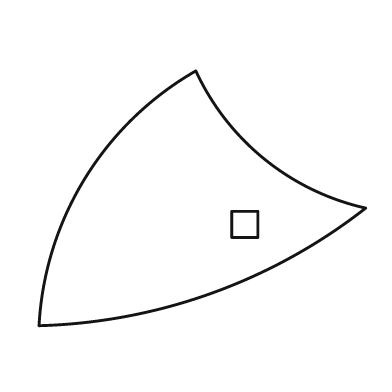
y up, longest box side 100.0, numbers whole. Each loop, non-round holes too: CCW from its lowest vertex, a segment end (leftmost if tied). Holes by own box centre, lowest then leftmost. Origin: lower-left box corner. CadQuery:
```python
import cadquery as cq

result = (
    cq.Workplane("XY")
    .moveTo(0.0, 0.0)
    .threePointArc((53.0, 10.0), (100.0, 36.0))
    .threePointArc((69.0, 51.0), (48.0, 78.0))
    .threePointArc((14.0, 45.0), (0.0, 0.0))
    .close()
    .moveTo(59.0, 27.0)
    .lineTo(67.0, 27.0)
    .lineTo(67.0, 35.0)
    .lineTo(59.0, 35.0)
    .close()
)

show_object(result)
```